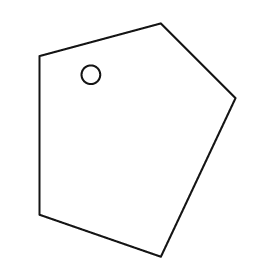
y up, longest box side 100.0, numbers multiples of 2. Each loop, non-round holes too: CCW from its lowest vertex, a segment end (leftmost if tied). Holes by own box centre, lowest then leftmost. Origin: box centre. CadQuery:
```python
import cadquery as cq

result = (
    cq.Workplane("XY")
    .moveTo(10.0, -50.0)
    .lineTo(42.0, 18.0)
    .lineTo(10.0, 50.0)
    .lineTo(-42.0, 36.0)
    .lineTo(-42.0, -32.0)
    .close()
    .moveTo(-20.0, 28.0)
    .circle(4.0)
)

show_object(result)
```